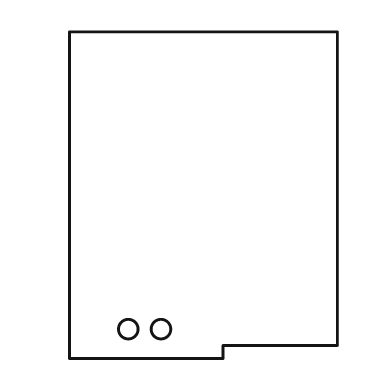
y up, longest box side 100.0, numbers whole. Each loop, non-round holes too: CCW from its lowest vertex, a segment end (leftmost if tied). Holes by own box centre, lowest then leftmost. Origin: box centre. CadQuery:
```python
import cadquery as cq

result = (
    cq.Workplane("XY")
    .moveTo(-41.0, -50.0)
    .lineTo(6.0, -50.0)
    .lineTo(6.0, -46.0)
    .lineTo(41.0, -46.0)
    .lineTo(41.0, 50.0)
    .lineTo(-41.0, 50.0)
    .close()
    .moveTo(-23.0, -41.0)
    .circle(3.0)
    .moveTo(-13.0, -41.0)
    .circle(3.0)
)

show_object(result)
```